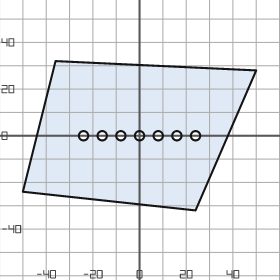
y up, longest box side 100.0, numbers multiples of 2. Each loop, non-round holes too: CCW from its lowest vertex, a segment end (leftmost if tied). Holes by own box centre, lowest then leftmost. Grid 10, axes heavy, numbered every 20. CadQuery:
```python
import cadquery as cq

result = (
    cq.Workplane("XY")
    .moveTo(24.0, -32.0)
    .lineTo(50.0, 28.0)
    .lineTo(-36.0, 32.0)
    .lineTo(-50.0, -24.0)
    .close()
    .moveTo(-24.0, 0.0)
    .circle(2.0)
    .moveTo(-16.0, 0.0)
    .circle(2.0)
    .moveTo(-8.0, 0.0)
    .circle(2.0)
    .moveTo(0.0, 0.0)
    .circle(2.0)
    .moveTo(8.0, 0.0)
    .circle(2.0)
    .moveTo(16.0, 0.0)
    .circle(2.0)
    .moveTo(24.0, 0.0)
    .circle(2.0)
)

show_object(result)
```